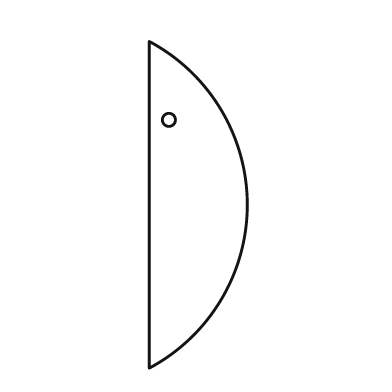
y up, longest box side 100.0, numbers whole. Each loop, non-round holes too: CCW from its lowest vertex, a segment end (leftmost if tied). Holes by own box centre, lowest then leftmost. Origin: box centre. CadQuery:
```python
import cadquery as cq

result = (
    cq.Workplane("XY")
    .moveTo(-15.0, -50.0)
    .threePointArc((15.0, 0.0), (-15.0, 50.0))
    .close()
    .moveTo(-9.0, 26.0)
    .circle(2.0)
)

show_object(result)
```